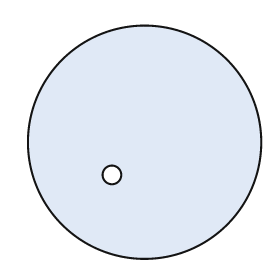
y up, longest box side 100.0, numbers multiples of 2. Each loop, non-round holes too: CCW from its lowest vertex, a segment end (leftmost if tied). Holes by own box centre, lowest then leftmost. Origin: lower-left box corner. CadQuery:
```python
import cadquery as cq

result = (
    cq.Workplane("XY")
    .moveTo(50.0, 50.0)
    .circle(50.0)
    .moveTo(36.0, 36.0)
    .circle(4.0)
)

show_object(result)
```